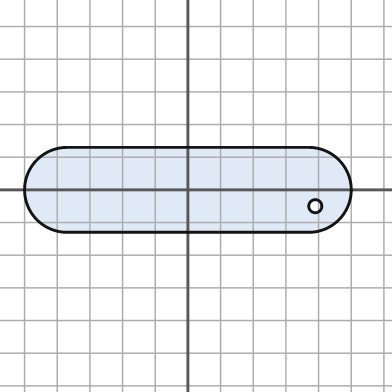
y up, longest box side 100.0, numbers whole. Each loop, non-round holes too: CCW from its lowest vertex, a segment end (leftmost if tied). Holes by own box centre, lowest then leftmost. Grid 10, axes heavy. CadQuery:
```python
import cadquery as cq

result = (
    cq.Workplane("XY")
    .moveTo(-37.0, -13.0)
    .lineTo(37.0, -13.0)
    .threePointArc((50.0, 0.0), (37.0, 13.0))
    .lineTo(-37.0, 13.0)
    .threePointArc((-50.0, 0.0), (-37.0, -13.0))
    .close()
    .moveTo(39.0, -5.0)
    .circle(2.0)
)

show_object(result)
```